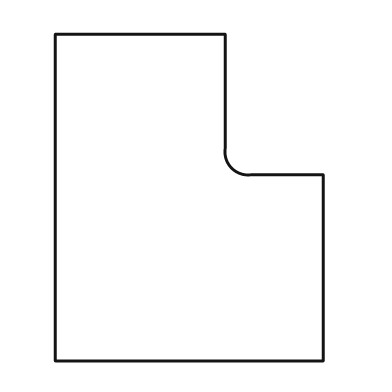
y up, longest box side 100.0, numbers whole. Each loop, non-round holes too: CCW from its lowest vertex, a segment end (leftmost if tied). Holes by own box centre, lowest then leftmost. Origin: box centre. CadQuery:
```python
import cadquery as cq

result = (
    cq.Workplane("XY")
    .moveTo(-41.0, -50.0)
    .lineTo(41.0, -50.0)
    .lineTo(41.0, 7.0)
    .lineTo(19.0, 7.0)
    .threePointArc((13.0, 9.0), (11.0, 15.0))
    .lineTo(11.0, 50.0)
    .lineTo(-41.0, 50.0)
    .close()
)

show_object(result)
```